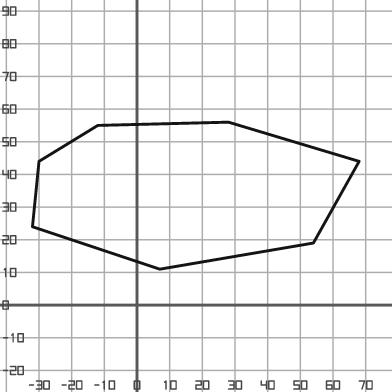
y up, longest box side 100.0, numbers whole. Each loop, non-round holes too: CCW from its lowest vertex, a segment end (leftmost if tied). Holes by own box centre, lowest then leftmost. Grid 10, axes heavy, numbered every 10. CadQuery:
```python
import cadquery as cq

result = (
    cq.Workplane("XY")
    .moveTo(7.0, 11.0)
    .lineTo(54.0, 19.0)
    .lineTo(68.0, 44.0)
    .lineTo(28.0, 56.0)
    .lineTo(-12.0, 55.0)
    .lineTo(-30.0, 44.0)
    .lineTo(-32.0, 24.0)
    .close()
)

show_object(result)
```